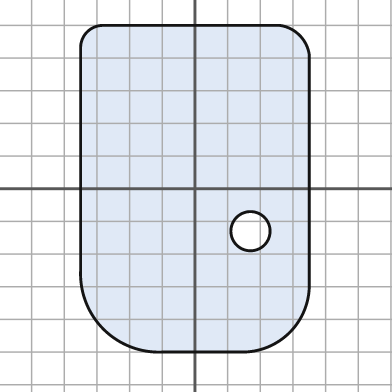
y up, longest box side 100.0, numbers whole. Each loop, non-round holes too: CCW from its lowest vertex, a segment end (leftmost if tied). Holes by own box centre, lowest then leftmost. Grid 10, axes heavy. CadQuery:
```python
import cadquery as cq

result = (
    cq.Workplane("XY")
    .moveTo(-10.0, -50.0)
    .lineTo(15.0, -50.0)
    .threePointArc((29.0, -44.0), (35.0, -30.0))
    .lineTo(35.0, 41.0)
    .threePointArc((32.0, 47.0), (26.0, 50.0))
    .lineTo(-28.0, 50.0)
    .threePointArc((-33.0, 48.0), (-35.0, 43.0))
    .lineTo(-35.0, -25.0)
    .threePointArc((-28.0, -43.0), (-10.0, -50.0))
    .close()
    .moveTo(17.0, -13.0)
    .circle(6.0)
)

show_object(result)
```